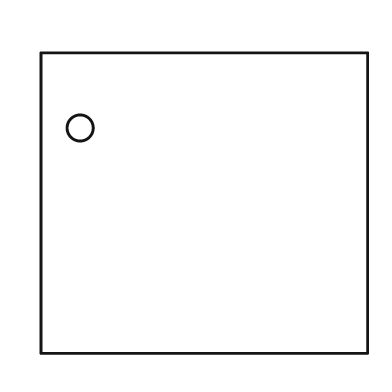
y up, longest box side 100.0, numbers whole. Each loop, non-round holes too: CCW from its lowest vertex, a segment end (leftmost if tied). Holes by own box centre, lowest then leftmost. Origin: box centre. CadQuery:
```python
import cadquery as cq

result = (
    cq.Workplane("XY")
    .moveTo(-50.0, -46.0)
    .lineTo(50.0, -46.0)
    .lineTo(50.0, 46.0)
    .lineTo(-50.0, 46.0)
    .close()
    .moveTo(-38.0, 23.0)
    .circle(4.0)
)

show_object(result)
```